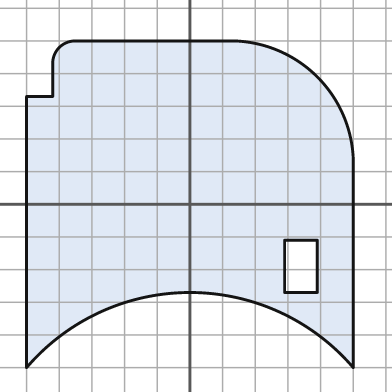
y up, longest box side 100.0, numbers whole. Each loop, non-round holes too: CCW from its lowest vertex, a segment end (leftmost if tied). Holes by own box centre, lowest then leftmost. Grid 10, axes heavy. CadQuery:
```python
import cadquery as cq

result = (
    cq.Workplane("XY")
    .moveTo(-50.0, -50.0)
    .threePointArc((0.0, -27.0), (50.0, -50.0))
    .lineTo(50.0, 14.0)
    .threePointArc((39.0, 39.0), (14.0, 50.0))
    .lineTo(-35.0, 50.0)
    .threePointArc((-40.0, 48.0), (-42.0, 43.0))
    .lineTo(-42.0, 33.0)
    .lineTo(-50.0, 33.0)
    .close()
    .moveTo(29.0, -27.0)
    .lineTo(39.0, -27.0)
    .lineTo(39.0, -11.0)
    .lineTo(29.0, -11.0)
    .close()
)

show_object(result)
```